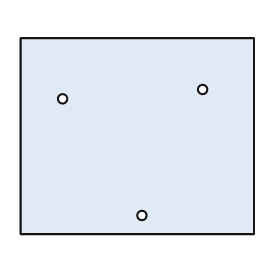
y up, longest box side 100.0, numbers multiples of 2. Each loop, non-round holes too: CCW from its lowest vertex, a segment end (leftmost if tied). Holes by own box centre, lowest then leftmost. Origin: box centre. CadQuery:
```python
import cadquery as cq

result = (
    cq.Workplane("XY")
    .moveTo(-50.0, -42.0)
    .lineTo(50.0, -42.0)
    .lineTo(50.0, 42.0)
    .lineTo(-50.0, 42.0)
    .close()
    .moveTo(2.0, -34.0)
    .circle(2.0)
    .moveTo(-32.0, 16.0)
    .circle(2.0)
    .moveTo(28.0, 20.0)
    .circle(2.0)
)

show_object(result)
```